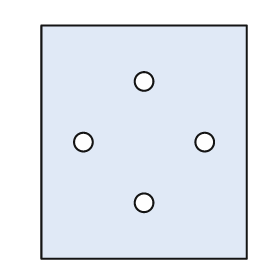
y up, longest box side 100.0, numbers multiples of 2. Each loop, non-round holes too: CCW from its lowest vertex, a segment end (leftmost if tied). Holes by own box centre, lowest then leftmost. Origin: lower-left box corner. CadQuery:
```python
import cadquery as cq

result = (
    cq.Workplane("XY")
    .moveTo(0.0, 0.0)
    .lineTo(88.0, 0.0)
    .lineTo(88.0, 100.0)
    .lineTo(0.0, 100.0)
    .close()
    .moveTo(44.0, 24.0)
    .circle(4.0)
    .moveTo(18.0, 50.0)
    .circle(4.0)
    .moveTo(70.0, 50.0)
    .circle(4.0)
    .moveTo(44.0, 76.0)
    .circle(4.0)
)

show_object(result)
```